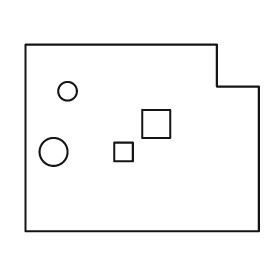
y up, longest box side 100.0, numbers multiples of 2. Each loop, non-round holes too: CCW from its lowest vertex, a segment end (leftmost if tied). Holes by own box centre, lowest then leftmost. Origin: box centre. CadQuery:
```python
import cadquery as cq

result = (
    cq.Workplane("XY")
    .moveTo(-50.0, -40.0)
    .lineTo(50.0, -40.0)
    .lineTo(50.0, 22.0)
    .lineTo(32.0, 22.0)
    .lineTo(32.0, 40.0)
    .lineTo(-50.0, 40.0)
    .close()
    .moveTo(-38.0, -6.0)
    .circle(6.0)
    .moveTo(-12.0, -10.0)
    .lineTo(-4.0, -10.0)
    .lineTo(-4.0, -2.0)
    .lineTo(-12.0, -2.0)
    .close()
    .moveTo(0.0, 0.0)
    .lineTo(12.0, 0.0)
    .lineTo(12.0, 12.0)
    .lineTo(0.0, 12.0)
    .close()
    .moveTo(-32.0, 20.0)
    .circle(4.0)
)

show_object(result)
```